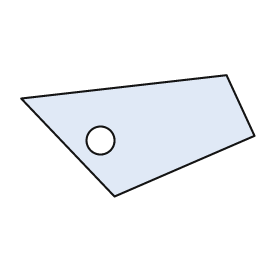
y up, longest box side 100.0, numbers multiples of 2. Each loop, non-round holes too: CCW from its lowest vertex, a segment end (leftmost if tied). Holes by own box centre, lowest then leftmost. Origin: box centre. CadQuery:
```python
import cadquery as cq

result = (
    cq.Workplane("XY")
    .moveTo(-10.0, -26.0)
    .lineTo(50.0, 0.0)
    .lineTo(38.0, 26.0)
    .lineTo(-50.0, 16.0)
    .close()
    .moveTo(-16.0, -2.0)
    .circle(6.0)
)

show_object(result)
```